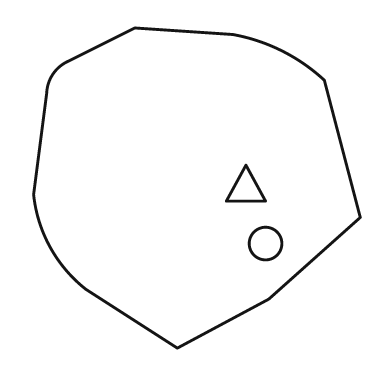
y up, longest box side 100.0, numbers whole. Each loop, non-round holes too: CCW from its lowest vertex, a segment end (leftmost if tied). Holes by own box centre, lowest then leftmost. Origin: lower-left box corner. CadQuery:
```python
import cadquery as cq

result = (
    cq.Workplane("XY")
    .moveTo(44.0, 0.0)
    .lineTo(72.0, 15.0)
    .lineTo(100.0, 40.0)
    .lineTo(89.0, 82.0)
    .threePointArc((76.0, 91.0), (61.0, 96.0))
    .lineTo(31.0, 98.0)
    .lineTo(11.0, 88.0)
    .threePointArc((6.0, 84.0), (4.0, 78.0))
    .lineTo(0.0, 47.0)
    .threePointArc((5.0, 31.0), (16.0, 18.0))
    .close()
    .moveTo(71.0, 32.0)
    .circle(5.0)
    .moveTo(59.0, 45.0)
    .lineTo(71.0, 45.0)
    .lineTo(65.0, 56.0)
    .close()
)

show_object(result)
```